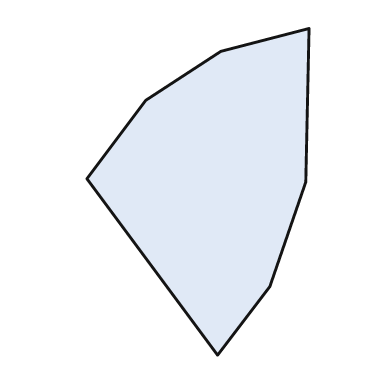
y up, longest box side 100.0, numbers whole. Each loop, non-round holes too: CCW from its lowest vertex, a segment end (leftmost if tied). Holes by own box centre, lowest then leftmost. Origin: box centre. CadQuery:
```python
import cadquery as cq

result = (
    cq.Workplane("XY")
    .moveTo(6.0, -50.0)
    .lineTo(22.0, -29.0)
    .lineTo(33.0, 3.0)
    .lineTo(34.0, 50.0)
    .lineTo(7.0, 43.0)
    .lineTo(-16.0, 28.0)
    .lineTo(-34.0, 4.0)
    .close()
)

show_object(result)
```